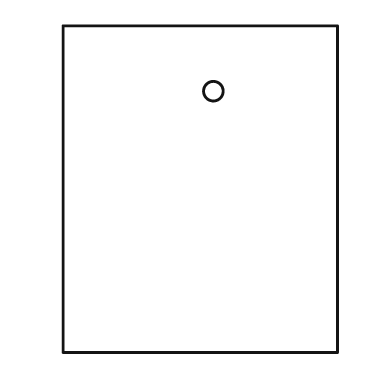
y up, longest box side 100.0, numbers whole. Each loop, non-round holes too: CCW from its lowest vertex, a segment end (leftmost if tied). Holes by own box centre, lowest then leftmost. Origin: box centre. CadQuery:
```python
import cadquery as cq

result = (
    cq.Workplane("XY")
    .moveTo(-42.0, -50.0)
    .lineTo(42.0, -50.0)
    .lineTo(42.0, 50.0)
    .lineTo(-42.0, 50.0)
    .close()
    .moveTo(4.0, 30.0)
    .circle(3.0)
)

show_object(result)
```